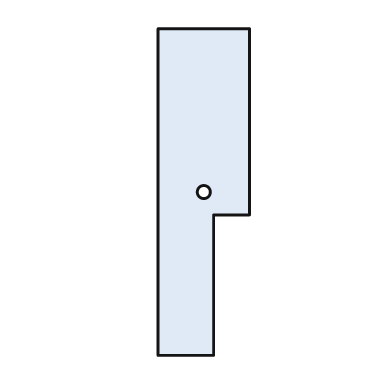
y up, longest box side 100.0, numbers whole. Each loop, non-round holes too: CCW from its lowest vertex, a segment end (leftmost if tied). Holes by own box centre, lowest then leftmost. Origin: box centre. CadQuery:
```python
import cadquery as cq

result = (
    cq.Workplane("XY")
    .moveTo(-14.0, -50.0)
    .lineTo(3.0, -50.0)
    .lineTo(3.0, -7.0)
    .lineTo(14.0, -7.0)
    .lineTo(14.0, 50.0)
    .lineTo(-14.0, 50.0)
    .close()
    .moveTo(0.0, 0.0)
    .circle(2.0)
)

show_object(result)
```